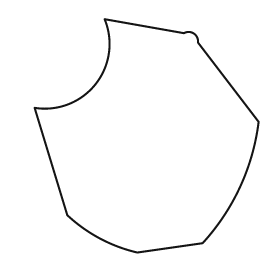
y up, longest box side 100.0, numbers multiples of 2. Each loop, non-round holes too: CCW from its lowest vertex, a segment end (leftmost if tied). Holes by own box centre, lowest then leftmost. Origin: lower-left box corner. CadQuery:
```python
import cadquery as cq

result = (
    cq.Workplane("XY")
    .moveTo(44.0, 0.0)
    .lineTo(72.0, 4.0)
    .threePointArc((88.0, 28.0), (96.0, 56.0))
    .lineTo(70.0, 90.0)
    .threePointArc((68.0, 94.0), (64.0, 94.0))
    .lineTo(30.0, 100.0)
    .threePointArc((26.0, 72.0), (0.0, 62.0))
    .lineTo(14.0, 16.0)
    .threePointArc((28.0, 6.0), (44.0, 0.0))
    .close()
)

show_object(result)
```